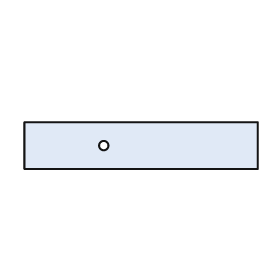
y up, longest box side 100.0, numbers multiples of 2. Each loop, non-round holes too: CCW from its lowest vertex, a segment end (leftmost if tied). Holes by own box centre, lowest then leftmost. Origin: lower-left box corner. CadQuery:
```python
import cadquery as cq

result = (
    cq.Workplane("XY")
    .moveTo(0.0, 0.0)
    .lineTo(100.0, 0.0)
    .lineTo(100.0, 20.0)
    .lineTo(0.0, 20.0)
    .close()
    .moveTo(34.0, 10.0)
    .circle(2.0)
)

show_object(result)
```